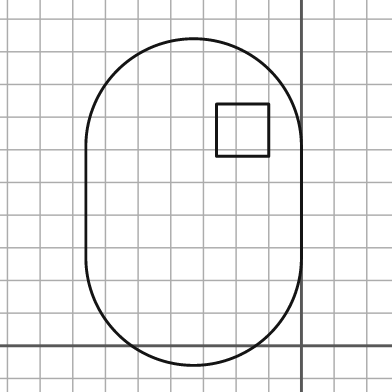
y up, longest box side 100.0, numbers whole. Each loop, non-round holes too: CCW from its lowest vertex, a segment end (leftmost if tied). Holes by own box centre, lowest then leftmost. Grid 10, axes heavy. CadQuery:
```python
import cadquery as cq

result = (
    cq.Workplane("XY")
    .moveTo(-66.0, 27.0)
    .threePointArc((-33.0, -6.0), (0.0, 27.0))
    .lineTo(0.0, 61.0)
    .threePointArc((-33.0, 94.0), (-66.0, 61.0))
    .close()
    .moveTo(-26.0, 58.0)
    .lineTo(-10.0, 58.0)
    .lineTo(-10.0, 74.0)
    .lineTo(-26.0, 74.0)
    .close()
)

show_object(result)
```